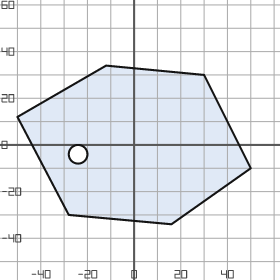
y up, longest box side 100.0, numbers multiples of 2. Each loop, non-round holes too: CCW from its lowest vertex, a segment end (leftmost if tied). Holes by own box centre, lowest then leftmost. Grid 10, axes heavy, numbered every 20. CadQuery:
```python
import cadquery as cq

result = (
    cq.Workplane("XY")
    .moveTo(16.0, -34.0)
    .lineTo(50.0, -10.0)
    .lineTo(30.0, 30.0)
    .lineTo(-12.0, 34.0)
    .lineTo(-50.0, 12.0)
    .lineTo(-28.0, -30.0)
    .close()
    .moveTo(-24.0, -4.0)
    .circle(4.0)
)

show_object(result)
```